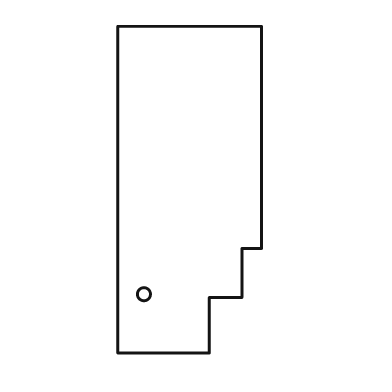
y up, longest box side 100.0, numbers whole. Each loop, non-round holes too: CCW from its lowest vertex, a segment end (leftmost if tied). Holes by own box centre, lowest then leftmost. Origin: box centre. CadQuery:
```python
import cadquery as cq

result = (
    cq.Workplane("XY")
    .moveTo(-22.0, -50.0)
    .lineTo(6.0, -50.0)
    .lineTo(6.0, -33.0)
    .lineTo(16.0, -33.0)
    .lineTo(16.0, -18.0)
    .lineTo(22.0, -18.0)
    .lineTo(22.0, 50.0)
    .lineTo(-22.0, 50.0)
    .close()
    .moveTo(-14.0, -32.0)
    .circle(2.0)
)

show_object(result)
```